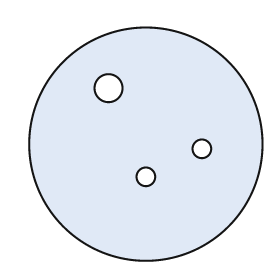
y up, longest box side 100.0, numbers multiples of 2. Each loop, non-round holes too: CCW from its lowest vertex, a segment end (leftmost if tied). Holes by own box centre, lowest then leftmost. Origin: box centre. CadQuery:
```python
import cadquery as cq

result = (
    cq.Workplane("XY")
    .moveTo(0.0, 0.0)
    .circle(50.0)
    .moveTo(0.0, -14.0)
    .circle(4.0)
    .moveTo(24.0, -2.0)
    .circle(4.0)
    .moveTo(-16.0, 24.0)
    .circle(6.0)
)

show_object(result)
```